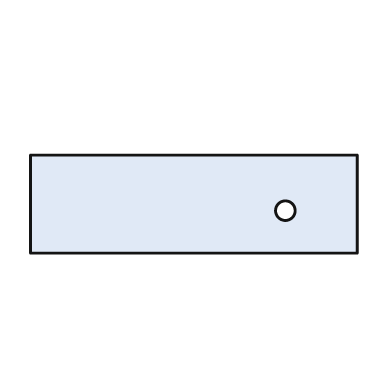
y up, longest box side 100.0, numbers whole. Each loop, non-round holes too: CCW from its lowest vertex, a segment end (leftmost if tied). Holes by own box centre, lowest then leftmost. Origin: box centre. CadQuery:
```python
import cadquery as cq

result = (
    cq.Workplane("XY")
    .moveTo(-50.0, -15.0)
    .lineTo(50.0, -15.0)
    .lineTo(50.0, 15.0)
    .lineTo(-50.0, 15.0)
    .close()
    .moveTo(28.0, -2.0)
    .circle(3.0)
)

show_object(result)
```